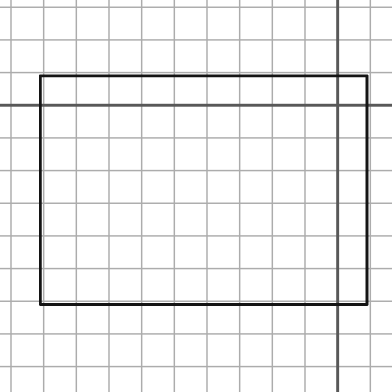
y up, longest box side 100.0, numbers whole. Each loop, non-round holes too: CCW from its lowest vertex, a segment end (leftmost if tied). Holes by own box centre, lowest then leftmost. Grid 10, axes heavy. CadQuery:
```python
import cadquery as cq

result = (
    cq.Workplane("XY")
    .moveTo(-91.0, -61.0)
    .lineTo(9.0, -61.0)
    .lineTo(9.0, 9.0)
    .lineTo(-91.0, 9.0)
    .close()
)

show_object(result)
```